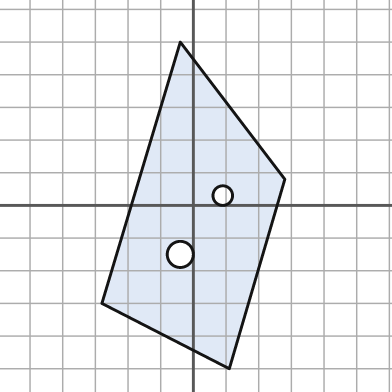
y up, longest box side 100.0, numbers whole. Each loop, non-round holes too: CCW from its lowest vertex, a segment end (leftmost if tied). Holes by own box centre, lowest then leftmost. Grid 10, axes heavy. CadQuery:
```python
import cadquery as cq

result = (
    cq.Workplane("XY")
    .moveTo(11.0, -50.0)
    .lineTo(28.0, 8.0)
    .lineTo(-4.0, 50.0)
    .lineTo(-28.0, -30.0)
    .close()
    .moveTo(-4.0, -15.0)
    .circle(4.0)
    .moveTo(9.0, 3.0)
    .circle(3.0)
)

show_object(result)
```